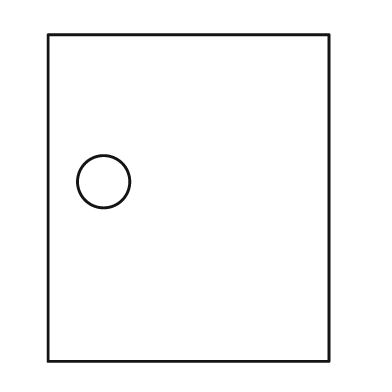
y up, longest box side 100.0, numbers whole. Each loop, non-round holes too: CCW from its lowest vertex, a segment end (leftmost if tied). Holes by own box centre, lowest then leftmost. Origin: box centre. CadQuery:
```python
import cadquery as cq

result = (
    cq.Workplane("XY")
    .moveTo(-43.0, -50.0)
    .lineTo(43.0, -50.0)
    .lineTo(43.0, 50.0)
    .lineTo(-43.0, 50.0)
    .close()
    .moveTo(-26.0, 5.0)
    .circle(8.0)
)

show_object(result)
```